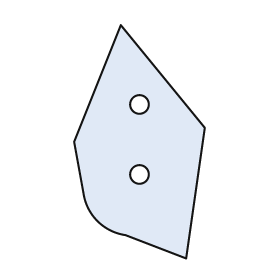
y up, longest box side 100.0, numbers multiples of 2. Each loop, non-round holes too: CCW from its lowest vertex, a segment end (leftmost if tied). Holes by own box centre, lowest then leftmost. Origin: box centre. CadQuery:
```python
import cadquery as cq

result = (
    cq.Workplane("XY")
    .moveTo(20.0, -50.0)
    .lineTo(28.0, 6.0)
    .lineTo(-8.0, 50.0)
    .lineTo(-28.0, 0.0)
    .lineTo(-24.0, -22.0)
    .threePointArc((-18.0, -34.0), (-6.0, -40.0))
    .close()
    .moveTo(0.0, -14.0)
    .circle(4.0)
    .moveTo(0.0, 16.0)
    .circle(4.0)
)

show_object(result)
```